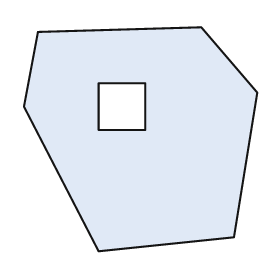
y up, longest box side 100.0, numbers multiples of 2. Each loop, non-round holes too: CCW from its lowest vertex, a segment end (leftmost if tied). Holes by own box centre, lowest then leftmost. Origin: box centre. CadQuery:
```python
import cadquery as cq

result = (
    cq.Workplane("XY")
    .moveTo(-18.0, -48.0)
    .lineTo(40.0, -42.0)
    .lineTo(50.0, 20.0)
    .lineTo(26.0, 48.0)
    .lineTo(-44.0, 46.0)
    .lineTo(-50.0, 14.0)
    .close()
    .moveTo(-18.0, 4.0)
    .lineTo(2.0, 4.0)
    .lineTo(2.0, 24.0)
    .lineTo(-18.0, 24.0)
    .close()
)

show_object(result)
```